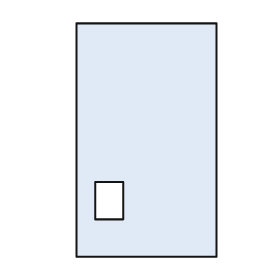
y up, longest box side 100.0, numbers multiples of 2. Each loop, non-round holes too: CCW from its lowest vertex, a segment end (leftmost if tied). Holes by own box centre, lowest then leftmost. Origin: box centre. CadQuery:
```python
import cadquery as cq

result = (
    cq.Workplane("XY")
    .moveTo(-30.0, -50.0)
    .lineTo(30.0, -50.0)
    .lineTo(30.0, 50.0)
    .lineTo(-30.0, 50.0)
    .close()
    .moveTo(-22.0, -34.0)
    .lineTo(-10.0, -34.0)
    .lineTo(-10.0, -18.0)
    .lineTo(-22.0, -18.0)
    .close()
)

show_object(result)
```